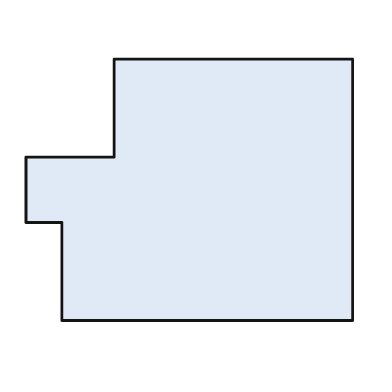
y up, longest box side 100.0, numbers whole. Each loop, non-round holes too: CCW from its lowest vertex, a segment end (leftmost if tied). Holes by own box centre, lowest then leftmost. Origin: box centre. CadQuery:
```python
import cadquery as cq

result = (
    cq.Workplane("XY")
    .moveTo(-39.0, -40.0)
    .lineTo(50.0, -40.0)
    .lineTo(50.0, 40.0)
    .lineTo(-23.0, 40.0)
    .lineTo(-23.0, 10.0)
    .lineTo(-50.0, 10.0)
    .lineTo(-50.0, -10.0)
    .lineTo(-39.0, -10.0)
    .close()
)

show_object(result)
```